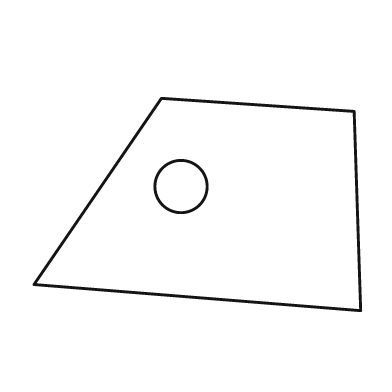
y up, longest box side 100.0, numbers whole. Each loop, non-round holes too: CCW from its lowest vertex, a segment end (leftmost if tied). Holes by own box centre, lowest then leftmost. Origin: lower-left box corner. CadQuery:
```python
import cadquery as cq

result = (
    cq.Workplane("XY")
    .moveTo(100.0, 0.0)
    .lineTo(98.0, 61.0)
    .lineTo(39.0, 65.0)
    .lineTo(0.0, 8.0)
    .close()
    .moveTo(45.0, 38.0)
    .circle(8.0)
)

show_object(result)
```